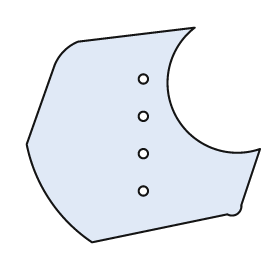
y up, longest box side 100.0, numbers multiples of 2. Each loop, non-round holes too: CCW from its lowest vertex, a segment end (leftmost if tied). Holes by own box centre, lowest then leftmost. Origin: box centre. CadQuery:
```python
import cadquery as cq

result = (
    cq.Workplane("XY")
    .moveTo(-22.0, -46.0)
    .lineTo(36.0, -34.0)
    .threePointArc((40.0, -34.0), (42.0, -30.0))
    .lineTo(50.0, -6.0)
    .threePointArc((14.0, 8.0), (22.0, 46.0))
    .lineTo(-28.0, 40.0)
    .threePointArc((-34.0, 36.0), (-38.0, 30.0))
    .lineTo(-50.0, -4.0)
    .threePointArc((-40.0, -28.0), (-22.0, -46.0))
    .close()
    .moveTo(0.0, -24.0)
    .circle(2.0)
    .moveTo(0.0, -8.0)
    .circle(2.0)
    .moveTo(0.0, 8.0)
    .circle(2.0)
    .moveTo(0.0, 24.0)
    .circle(2.0)
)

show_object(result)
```